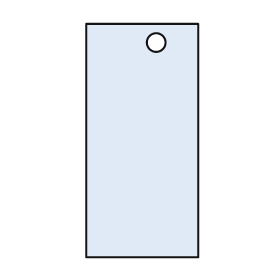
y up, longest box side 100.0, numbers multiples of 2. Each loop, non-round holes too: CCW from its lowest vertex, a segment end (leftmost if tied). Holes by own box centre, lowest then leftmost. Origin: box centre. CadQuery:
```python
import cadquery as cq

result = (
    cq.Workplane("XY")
    .moveTo(-24.0, -50.0)
    .lineTo(24.0, -50.0)
    .lineTo(24.0, 50.0)
    .lineTo(-24.0, 50.0)
    .close()
    .moveTo(6.0, 42.0)
    .circle(4.0)
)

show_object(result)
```